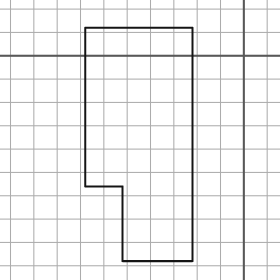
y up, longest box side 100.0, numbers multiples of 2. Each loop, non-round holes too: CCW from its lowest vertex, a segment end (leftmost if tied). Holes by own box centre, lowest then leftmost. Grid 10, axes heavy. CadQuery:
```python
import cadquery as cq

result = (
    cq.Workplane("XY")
    .moveTo(-52.0, -88.0)
    .lineTo(-22.0, -88.0)
    .lineTo(-22.0, 12.0)
    .lineTo(-68.0, 12.0)
    .lineTo(-68.0, -56.0)
    .lineTo(-52.0, -56.0)
    .close()
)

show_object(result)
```